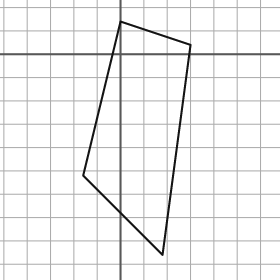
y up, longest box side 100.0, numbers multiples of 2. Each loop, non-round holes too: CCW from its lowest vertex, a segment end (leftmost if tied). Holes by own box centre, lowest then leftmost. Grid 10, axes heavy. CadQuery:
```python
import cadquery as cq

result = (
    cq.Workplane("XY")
    .moveTo(18.0, -86.0)
    .lineTo(30.0, 4.0)
    .lineTo(0.0, 14.0)
    .lineTo(-16.0, -52.0)
    .close()
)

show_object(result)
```